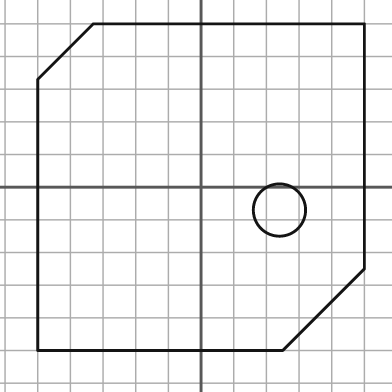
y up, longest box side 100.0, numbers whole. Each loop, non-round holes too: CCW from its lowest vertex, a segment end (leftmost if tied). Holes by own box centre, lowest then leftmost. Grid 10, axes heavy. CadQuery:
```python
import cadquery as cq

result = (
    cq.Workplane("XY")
    .moveTo(-50.0, -50.0)
    .lineTo(25.0, -50.0)
    .lineTo(50.0, -25.0)
    .lineTo(50.0, 50.0)
    .lineTo(-33.0, 50.0)
    .lineTo(-50.0, 33.0)
    .close()
    .moveTo(24.0, -7.0)
    .circle(8.0)
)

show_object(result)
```